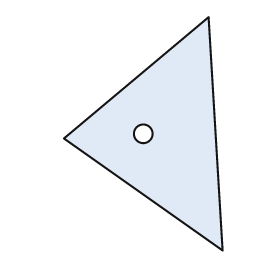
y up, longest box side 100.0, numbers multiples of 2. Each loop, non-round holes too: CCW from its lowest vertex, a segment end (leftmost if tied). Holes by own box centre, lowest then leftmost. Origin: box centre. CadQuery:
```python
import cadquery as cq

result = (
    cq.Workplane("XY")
    .moveTo(34.0, -50.0)
    .lineTo(28.0, 50.0)
    .lineTo(-34.0, -2.0)
    .close()
    .moveTo(0.0, 0.0)
    .circle(4.0)
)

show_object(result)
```